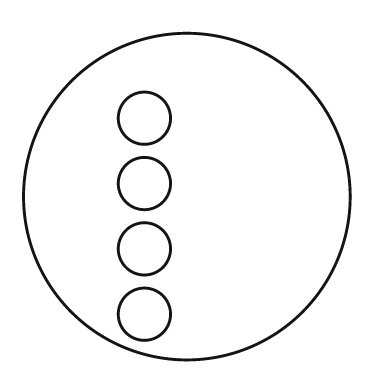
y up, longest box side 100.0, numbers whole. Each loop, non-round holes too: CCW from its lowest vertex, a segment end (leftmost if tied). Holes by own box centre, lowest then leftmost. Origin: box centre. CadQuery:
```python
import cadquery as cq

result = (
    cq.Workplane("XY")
    .moveTo(0.0, 0.0)
    .circle(50.0)
    .moveTo(-13.0, -36.0)
    .circle(8.0)
    .moveTo(-13.0, -16.0)
    .circle(8.0)
    .moveTo(-13.0, 4.0)
    .circle(8.0)
    .moveTo(-13.0, 24.0)
    .circle(8.0)
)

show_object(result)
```